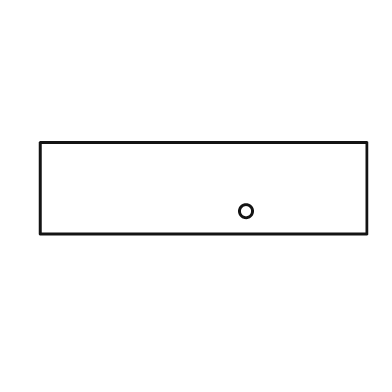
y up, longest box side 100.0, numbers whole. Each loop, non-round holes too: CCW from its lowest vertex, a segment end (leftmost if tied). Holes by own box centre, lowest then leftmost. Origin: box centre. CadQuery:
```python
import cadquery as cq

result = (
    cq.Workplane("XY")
    .moveTo(-50.0, -14.0)
    .lineTo(50.0, -14.0)
    .lineTo(50.0, 14.0)
    .lineTo(-50.0, 14.0)
    .close()
    .moveTo(13.0, -7.0)
    .circle(2.0)
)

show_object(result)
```